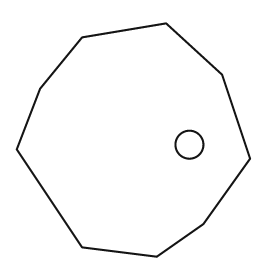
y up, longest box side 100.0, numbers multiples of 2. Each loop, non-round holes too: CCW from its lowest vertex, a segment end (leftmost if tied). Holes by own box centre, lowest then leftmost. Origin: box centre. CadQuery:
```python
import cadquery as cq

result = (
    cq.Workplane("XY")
    .moveTo(10.0, -50.0)
    .lineTo(30.0, -36.0)
    .lineTo(50.0, -8.0)
    .lineTo(38.0, 28.0)
    .lineTo(14.0, 50.0)
    .lineTo(-22.0, 44.0)
    .lineTo(-40.0, 22.0)
    .lineTo(-50.0, -4.0)
    .lineTo(-22.0, -46.0)
    .close()
    .moveTo(24.0, -2.0)
    .circle(6.0)
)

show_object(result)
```